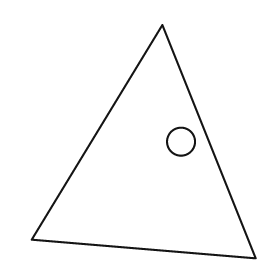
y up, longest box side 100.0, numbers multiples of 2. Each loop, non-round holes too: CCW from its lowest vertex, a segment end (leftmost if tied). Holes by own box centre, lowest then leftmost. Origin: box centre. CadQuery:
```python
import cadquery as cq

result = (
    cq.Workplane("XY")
    .moveTo(48.0, -50.0)
    .lineTo(8.0, 50.0)
    .lineTo(-48.0, -42.0)
    .close()
    .moveTo(16.0, 0.0)
    .circle(6.0)
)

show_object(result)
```